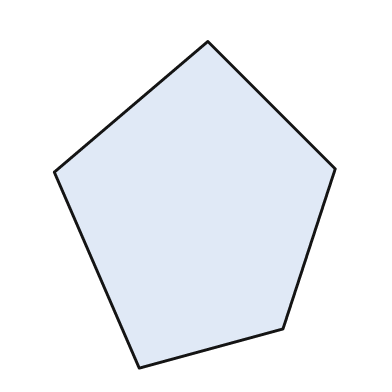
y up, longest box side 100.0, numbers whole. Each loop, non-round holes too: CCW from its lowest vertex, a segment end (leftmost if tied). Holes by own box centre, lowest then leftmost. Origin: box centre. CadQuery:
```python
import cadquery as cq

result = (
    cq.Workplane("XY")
    .moveTo(-17.0, -50.0)
    .lineTo(27.0, -38.0)
    .lineTo(43.0, 11.0)
    .lineTo(4.0, 50.0)
    .lineTo(-43.0, 10.0)
    .close()
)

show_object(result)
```